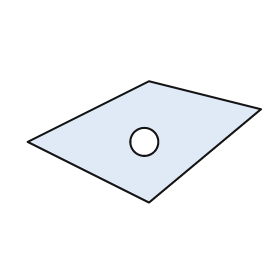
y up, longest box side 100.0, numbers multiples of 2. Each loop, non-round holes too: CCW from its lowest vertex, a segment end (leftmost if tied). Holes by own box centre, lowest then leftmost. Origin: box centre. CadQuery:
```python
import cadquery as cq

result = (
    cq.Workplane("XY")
    .moveTo(2.0, -26.0)
    .lineTo(50.0, 14.0)
    .lineTo(2.0, 26.0)
    .lineTo(-50.0, 0.0)
    .close()
    .moveTo(0.0, 0.0)
    .circle(6.0)
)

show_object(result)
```